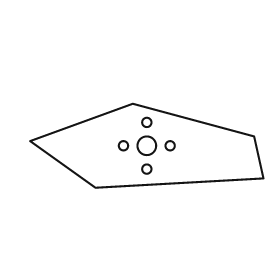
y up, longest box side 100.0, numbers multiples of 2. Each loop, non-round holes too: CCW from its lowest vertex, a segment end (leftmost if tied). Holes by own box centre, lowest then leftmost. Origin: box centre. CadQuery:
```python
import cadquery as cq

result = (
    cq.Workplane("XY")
    .moveTo(-22.0, -18.0)
    .lineTo(50.0, -14.0)
    .lineTo(46.0, 4.0)
    .lineTo(-6.0, 18.0)
    .lineTo(-50.0, 2.0)
    .close()
    .moveTo(0.0, -10.0)
    .circle(2.0)
    .moveTo(-10.0, 0.0)
    .circle(2.0)
    .moveTo(0.0, 0.0)
    .circle(4.0)
    .moveTo(10.0, 0.0)
    .circle(2.0)
    .moveTo(0.0, 10.0)
    .circle(2.0)
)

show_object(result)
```